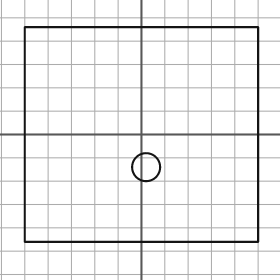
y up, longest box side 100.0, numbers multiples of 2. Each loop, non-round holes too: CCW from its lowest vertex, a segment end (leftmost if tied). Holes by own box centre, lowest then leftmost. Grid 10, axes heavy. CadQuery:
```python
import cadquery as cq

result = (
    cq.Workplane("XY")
    .moveTo(-50.0, -46.0)
    .lineTo(50.0, -46.0)
    .lineTo(50.0, 46.0)
    .lineTo(-50.0, 46.0)
    .close()
    .moveTo(2.0, -14.0)
    .circle(6.0)
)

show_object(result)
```